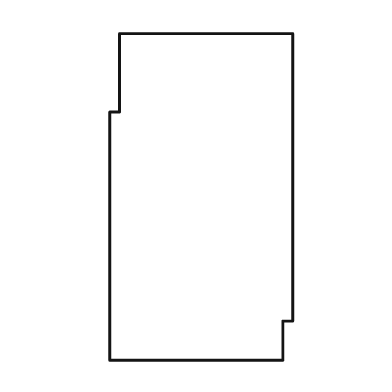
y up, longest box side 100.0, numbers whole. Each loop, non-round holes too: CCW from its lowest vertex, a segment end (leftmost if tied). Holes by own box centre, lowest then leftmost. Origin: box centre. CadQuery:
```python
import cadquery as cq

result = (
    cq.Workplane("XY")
    .moveTo(-28.0, -50.0)
    .lineTo(25.0, -50.0)
    .lineTo(25.0, -38.0)
    .lineTo(28.0, -38.0)
    .lineTo(28.0, 50.0)
    .lineTo(-25.0, 50.0)
    .lineTo(-25.0, 26.0)
    .lineTo(-28.0, 26.0)
    .close()
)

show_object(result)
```